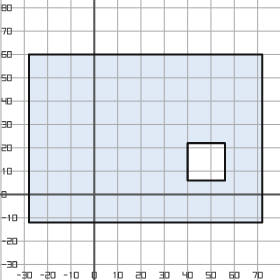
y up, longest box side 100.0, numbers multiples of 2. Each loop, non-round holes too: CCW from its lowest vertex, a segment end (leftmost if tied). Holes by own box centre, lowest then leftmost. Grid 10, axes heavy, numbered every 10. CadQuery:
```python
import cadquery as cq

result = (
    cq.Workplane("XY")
    .moveTo(-28.0, -12.0)
    .lineTo(72.0, -12.0)
    .lineTo(72.0, 60.0)
    .lineTo(-28.0, 60.0)
    .close()
    .moveTo(40.0, 6.0)
    .lineTo(56.0, 6.0)
    .lineTo(56.0, 22.0)
    .lineTo(40.0, 22.0)
    .close()
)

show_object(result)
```